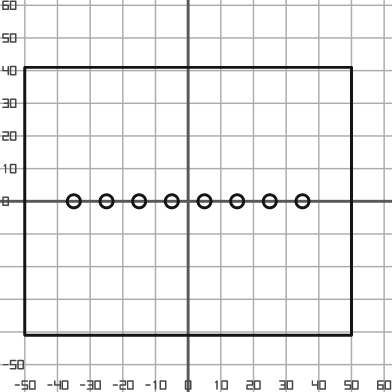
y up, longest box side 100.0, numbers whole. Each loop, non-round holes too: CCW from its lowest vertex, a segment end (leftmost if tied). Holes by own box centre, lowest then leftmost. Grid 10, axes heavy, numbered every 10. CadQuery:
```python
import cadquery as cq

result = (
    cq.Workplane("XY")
    .moveTo(-50.0, -41.0)
    .lineTo(50.0, -41.0)
    .lineTo(50.0, 41.0)
    .lineTo(-50.0, 41.0)
    .close()
    .moveTo(-35.0, 0.0)
    .circle(2.0)
    .moveTo(-25.0, 0.0)
    .circle(2.0)
    .moveTo(-15.0, 0.0)
    .circle(2.0)
    .moveTo(-5.0, 0.0)
    .circle(2.0)
    .moveTo(5.0, 0.0)
    .circle(2.0)
    .moveTo(15.0, 0.0)
    .circle(2.0)
    .moveTo(25.0, 0.0)
    .circle(2.0)
    .moveTo(35.0, 0.0)
    .circle(2.0)
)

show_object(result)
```